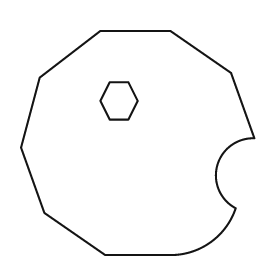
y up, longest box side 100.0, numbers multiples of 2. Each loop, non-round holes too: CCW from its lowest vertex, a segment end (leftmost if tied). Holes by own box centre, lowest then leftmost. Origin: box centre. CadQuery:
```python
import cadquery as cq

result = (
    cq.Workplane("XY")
    .moveTo(-14.0, -48.0)
    .lineTo(16.0, -48.0)
    .threePointArc((32.0, -42.0), (42.0, -28.0))
    .threePointArc((34.0, -10.0), (50.0, 2.0))
    .lineTo(40.0, 30.0)
    .lineTo(14.0, 48.0)
    .lineTo(-16.0, 48.0)
    .lineTo(-42.0, 28.0)
    .lineTo(-50.0, -2.0)
    .lineTo(-40.0, -30.0)
    .close()
    .moveTo(-12.0, 10.0)
    .lineTo(-4.0, 10.0)
    .lineTo(0.0, 18.0)
    .lineTo(-4.0, 26.0)
    .lineTo(-12.0, 26.0)
    .lineTo(-16.0, 18.0)
    .close()
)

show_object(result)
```